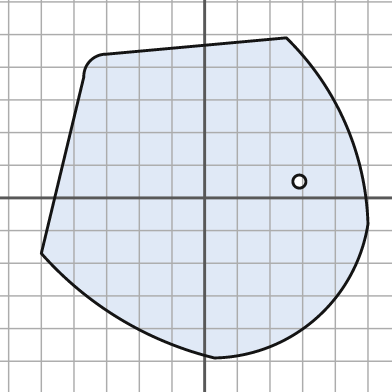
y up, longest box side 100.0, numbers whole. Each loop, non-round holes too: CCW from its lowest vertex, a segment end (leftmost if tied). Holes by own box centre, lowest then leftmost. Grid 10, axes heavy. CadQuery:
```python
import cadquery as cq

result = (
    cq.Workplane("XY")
    .moveTo(3.0, -49.0)
    .threePointArc((34.0, -37.0), (50.0, -8.0))
    .threePointArc((43.0, 23.0), (25.0, 49.0))
    .lineTo(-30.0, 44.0)
    .threePointArc((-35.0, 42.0), (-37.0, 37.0))
    .lineTo(-50.0, -17.0)
    .threePointArc((-26.0, -37.0), (3.0, -49.0))
    .close()
    .moveTo(29.0, 5.0)
    .circle(2.0)
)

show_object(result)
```